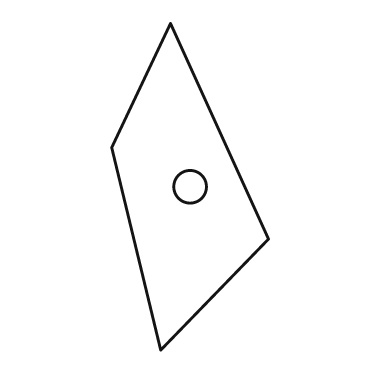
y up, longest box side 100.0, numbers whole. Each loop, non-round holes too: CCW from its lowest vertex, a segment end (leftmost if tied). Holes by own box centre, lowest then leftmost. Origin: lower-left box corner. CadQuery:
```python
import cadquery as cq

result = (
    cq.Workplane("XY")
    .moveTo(15.0, 0.0)
    .lineTo(48.0, 34.0)
    .lineTo(18.0, 100.0)
    .lineTo(0.0, 62.0)
    .close()
    .moveTo(24.0, 50.0)
    .circle(5.0)
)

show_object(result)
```